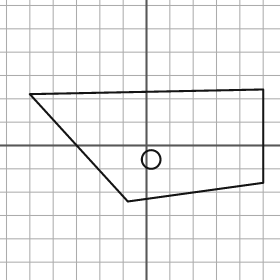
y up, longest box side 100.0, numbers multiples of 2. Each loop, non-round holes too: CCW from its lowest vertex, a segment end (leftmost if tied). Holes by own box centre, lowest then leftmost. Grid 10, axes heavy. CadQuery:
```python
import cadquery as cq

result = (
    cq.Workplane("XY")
    .moveTo(-8.0, -24.0)
    .lineTo(50.0, -16.0)
    .lineTo(50.0, 24.0)
    .lineTo(-50.0, 22.0)
    .close()
    .moveTo(2.0, -6.0)
    .circle(4.0)
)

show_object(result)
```